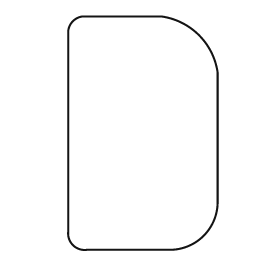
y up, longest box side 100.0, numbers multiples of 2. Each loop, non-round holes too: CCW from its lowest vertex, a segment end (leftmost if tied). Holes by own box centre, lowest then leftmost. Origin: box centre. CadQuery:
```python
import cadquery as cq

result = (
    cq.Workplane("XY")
    .moveTo(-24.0, -50.0)
    .lineTo(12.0, -50.0)
    .threePointArc((26.0, -44.0), (32.0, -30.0))
    .lineTo(32.0, 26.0)
    .threePointArc((24.0, 42.0), (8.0, 50.0))
    .lineTo(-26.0, 50.0)
    .threePointArc((-30.0, 48.0), (-32.0, 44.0))
    .lineTo(-32.0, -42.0)
    .threePointArc((-30.0, -48.0), (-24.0, -50.0))
    .close()
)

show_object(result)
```